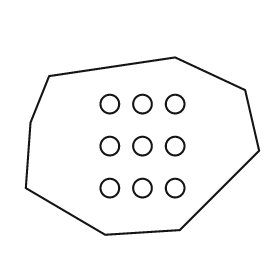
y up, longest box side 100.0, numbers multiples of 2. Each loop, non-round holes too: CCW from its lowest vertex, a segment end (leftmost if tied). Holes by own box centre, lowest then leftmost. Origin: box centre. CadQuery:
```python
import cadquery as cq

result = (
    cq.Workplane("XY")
    .moveTo(-16.0, -38.0)
    .lineTo(16.0, -36.0)
    .lineTo(50.0, -2.0)
    .lineTo(44.0, 24.0)
    .lineTo(14.0, 38.0)
    .lineTo(-40.0, 30.0)
    .lineTo(-48.0, 10.0)
    .lineTo(-50.0, -18.0)
    .close()
    .moveTo(-14.0, -18.0)
    .circle(4.0)
    .moveTo(0.0, -18.0)
    .circle(4.0)
    .moveTo(14.0, -18.0)
    .circle(4.0)
    .moveTo(-14.0, 0.0)
    .circle(4.0)
    .moveTo(0.0, 0.0)
    .circle(4.0)
    .moveTo(14.0, 0.0)
    .circle(4.0)
    .moveTo(-14.0, 18.0)
    .circle(4.0)
    .moveTo(0.0, 18.0)
    .circle(4.0)
    .moveTo(14.0, 18.0)
    .circle(4.0)
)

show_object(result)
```